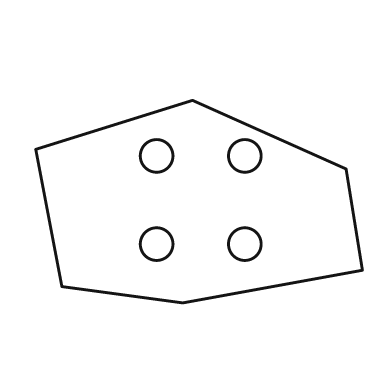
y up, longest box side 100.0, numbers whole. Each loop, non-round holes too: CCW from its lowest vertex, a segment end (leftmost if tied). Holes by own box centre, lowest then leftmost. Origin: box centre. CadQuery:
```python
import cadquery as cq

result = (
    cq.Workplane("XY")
    .moveTo(-5.0, -31.0)
    .lineTo(50.0, -21.0)
    .lineTo(45.0, 10.0)
    .lineTo(-2.0, 31.0)
    .lineTo(-50.0, 16.0)
    .lineTo(-42.0, -26.0)
    .close()
    .moveTo(-13.0, -13.0)
    .circle(5.0)
    .moveTo(14.0, -13.0)
    .circle(5.0)
    .moveTo(-13.0, 14.0)
    .circle(5.0)
    .moveTo(14.0, 14.0)
    .circle(5.0)
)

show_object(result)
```